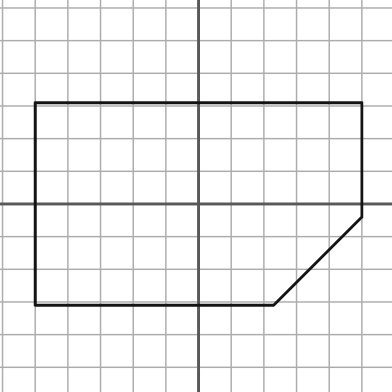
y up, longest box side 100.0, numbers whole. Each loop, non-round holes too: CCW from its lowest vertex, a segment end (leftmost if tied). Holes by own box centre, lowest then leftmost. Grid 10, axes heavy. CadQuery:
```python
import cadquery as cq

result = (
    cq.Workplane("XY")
    .moveTo(-50.0, -31.0)
    .lineTo(23.0, -31.0)
    .lineTo(50.0, -4.0)
    .lineTo(50.0, 31.0)
    .lineTo(-50.0, 31.0)
    .close()
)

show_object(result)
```